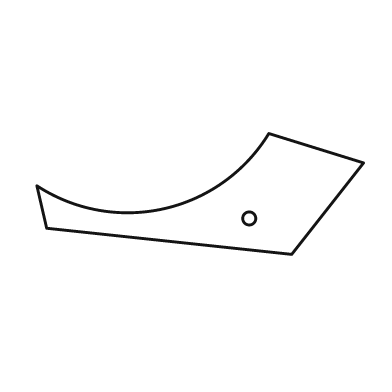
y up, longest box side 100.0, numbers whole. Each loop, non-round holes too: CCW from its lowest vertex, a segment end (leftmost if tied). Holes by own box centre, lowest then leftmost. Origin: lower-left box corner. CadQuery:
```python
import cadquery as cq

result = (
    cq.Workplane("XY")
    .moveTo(78.0, 0.0)
    .lineTo(100.0, 28.0)
    .lineTo(71.0, 37.0)
    .threePointArc((39.0, 14.0), (0.0, 21.0))
    .lineTo(3.0, 8.0)
    .close()
    .moveTo(65.0, 11.0)
    .circle(2.0)
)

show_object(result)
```